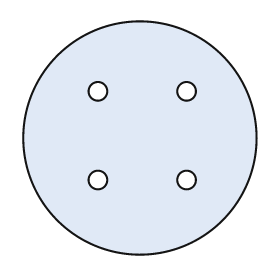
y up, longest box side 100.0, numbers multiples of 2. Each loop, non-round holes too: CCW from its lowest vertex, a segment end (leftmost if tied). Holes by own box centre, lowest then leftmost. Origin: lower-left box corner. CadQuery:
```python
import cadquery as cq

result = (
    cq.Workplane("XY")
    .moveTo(50.0, 50.0)
    .circle(50.0)
    .moveTo(32.0, 32.0)
    .circle(4.0)
    .moveTo(70.0, 32.0)
    .circle(4.0)
    .moveTo(32.0, 70.0)
    .circle(4.0)
    .moveTo(70.0, 70.0)
    .circle(4.0)
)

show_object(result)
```